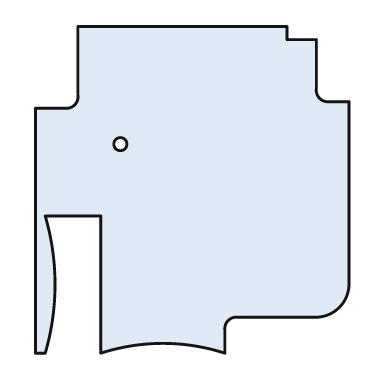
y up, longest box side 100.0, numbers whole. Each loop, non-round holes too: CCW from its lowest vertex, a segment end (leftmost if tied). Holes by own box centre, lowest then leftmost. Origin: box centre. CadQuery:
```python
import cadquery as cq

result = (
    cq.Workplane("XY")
    .moveTo(-48.0, -50.0)
    .lineTo(-45.0, -50.0)
    .threePointArc((-42.0, -29.0), (-45.0, -8.0))
    .lineTo(-28.0, -8.0)
    .lineTo(-28.0, -50.0)
    .threePointArc((-9.0, -47.0), (10.0, -50.0))
    .lineTo(10.0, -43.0)
    .threePointArc((11.0, -40.0), (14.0, -39.0))
    .lineTo(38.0, -39.0)
    .threePointArc((45.0, -36.0), (48.0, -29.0))
    .lineTo(48.0, 27.0)
    .lineTo(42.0, 27.0)
    .threePointArc((39.0, 28.0), (38.0, 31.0))
    .lineTo(38.0, 46.0)
    .lineTo(29.0, 46.0)
    .lineTo(29.0, 50.0)
    .lineTo(-35.0, 50.0)
    .lineTo(-35.0, 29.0)
    .threePointArc((-36.0, 26.0), (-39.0, 25.0))
    .lineTo(-48.0, 25.0)
    .close()
    .moveTo(-22.0, 14.0)
    .circle(2.0)
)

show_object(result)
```